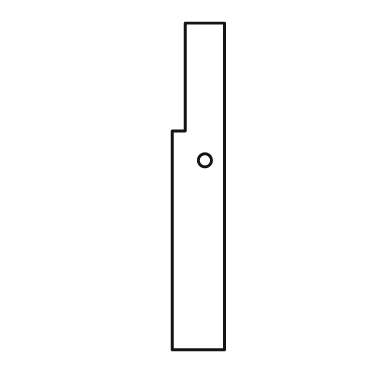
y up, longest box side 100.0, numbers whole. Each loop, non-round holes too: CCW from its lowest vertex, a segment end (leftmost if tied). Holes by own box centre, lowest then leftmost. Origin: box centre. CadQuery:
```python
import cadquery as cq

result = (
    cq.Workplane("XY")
    .moveTo(-8.0, -50.0)
    .lineTo(8.0, -50.0)
    .lineTo(8.0, 50.0)
    .lineTo(-4.0, 50.0)
    .lineTo(-4.0, 17.0)
    .lineTo(-8.0, 17.0)
    .close()
    .moveTo(2.0, 8.0)
    .circle(2.0)
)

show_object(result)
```